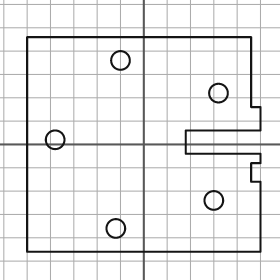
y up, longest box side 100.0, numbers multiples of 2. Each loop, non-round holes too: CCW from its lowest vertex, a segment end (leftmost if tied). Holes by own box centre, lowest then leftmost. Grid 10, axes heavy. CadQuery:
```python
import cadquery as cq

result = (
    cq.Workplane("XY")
    .moveTo(-50.0, -46.0)
    .lineTo(50.0, -46.0)
    .lineTo(50.0, -16.0)
    .lineTo(46.0, -16.0)
    .lineTo(46.0, -8.0)
    .lineTo(50.0, -8.0)
    .lineTo(50.0, -4.0)
    .lineTo(18.0, -4.0)
    .lineTo(18.0, 6.0)
    .lineTo(50.0, 6.0)
    .lineTo(50.0, 16.0)
    .lineTo(46.0, 16.0)
    .lineTo(46.0, 46.0)
    .lineTo(-50.0, 46.0)
    .close()
    .moveTo(-12.0, -36.0)
    .circle(4.0)
    .moveTo(30.0, -24.0)
    .circle(4.0)
    .moveTo(-38.0, 2.0)
    .circle(4.0)
    .moveTo(32.0, 22.0)
    .circle(4.0)
    .moveTo(-10.0, 36.0)
    .circle(4.0)
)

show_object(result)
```